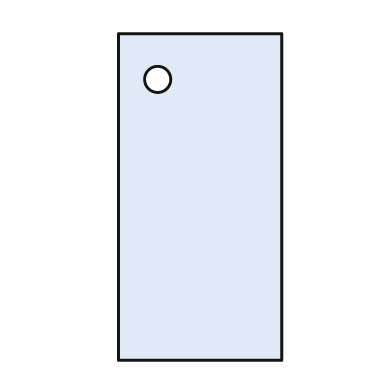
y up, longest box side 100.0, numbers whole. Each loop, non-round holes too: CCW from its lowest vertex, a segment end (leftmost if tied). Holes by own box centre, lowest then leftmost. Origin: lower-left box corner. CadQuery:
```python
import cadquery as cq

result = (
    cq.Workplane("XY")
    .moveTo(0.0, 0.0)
    .lineTo(50.0, 0.0)
    .lineTo(50.0, 100.0)
    .lineTo(0.0, 100.0)
    .close()
    .moveTo(12.0, 86.0)
    .circle(4.0)
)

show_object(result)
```